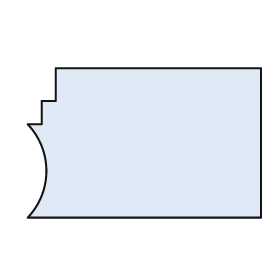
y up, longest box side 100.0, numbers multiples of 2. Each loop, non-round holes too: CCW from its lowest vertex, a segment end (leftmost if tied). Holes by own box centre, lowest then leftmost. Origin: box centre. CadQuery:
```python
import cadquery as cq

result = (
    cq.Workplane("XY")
    .moveTo(-50.0, -32.0)
    .lineTo(50.0, -32.0)
    .lineTo(50.0, 32.0)
    .lineTo(-38.0, 32.0)
    .lineTo(-38.0, 18.0)
    .lineTo(-44.0, 18.0)
    .lineTo(-44.0, 8.0)
    .lineTo(-50.0, 8.0)
    .threePointArc((-42.0, -12.0), (-50.0, -32.0))
    .close()
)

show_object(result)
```